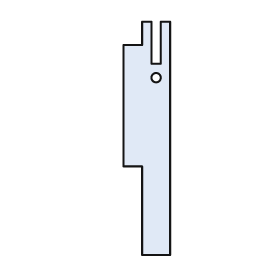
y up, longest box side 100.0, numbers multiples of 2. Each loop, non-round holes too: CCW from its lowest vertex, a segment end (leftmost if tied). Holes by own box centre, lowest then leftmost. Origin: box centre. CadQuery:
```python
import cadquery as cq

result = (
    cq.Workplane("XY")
    .moveTo(-2.0, -50.0)
    .lineTo(10.0, -50.0)
    .lineTo(10.0, 50.0)
    .lineTo(6.0, 50.0)
    .lineTo(6.0, 32.0)
    .lineTo(2.0, 32.0)
    .lineTo(2.0, 50.0)
    .lineTo(-2.0, 50.0)
    .lineTo(-2.0, 40.0)
    .lineTo(-10.0, 40.0)
    .lineTo(-10.0, -12.0)
    .lineTo(-2.0, -12.0)
    .close()
    .moveTo(4.0, 26.0)
    .circle(2.0)
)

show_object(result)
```